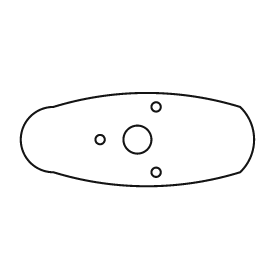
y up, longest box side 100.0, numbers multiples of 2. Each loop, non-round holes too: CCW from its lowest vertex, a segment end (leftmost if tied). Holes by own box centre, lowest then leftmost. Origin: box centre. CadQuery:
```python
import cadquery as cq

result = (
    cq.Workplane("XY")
    .moveTo(-36.0, -14.0)
    .threePointArc((4.0, -20.0), (44.0, -14.0))
    .threePointArc((50.0, 0.0), (44.0, 14.0))
    .threePointArc((4.0, 20.0), (-36.0, 14.0))
    .threePointArc((-50.0, 0.0), (-36.0, -14.0))
    .close()
    .moveTo(8.0, -14.0)
    .circle(2.0)
    .moveTo(-16.0, 0.0)
    .circle(2.0)
    .moveTo(0.0, 0.0)
    .circle(6.0)
    .moveTo(8.0, 14.0)
    .circle(2.0)
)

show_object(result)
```